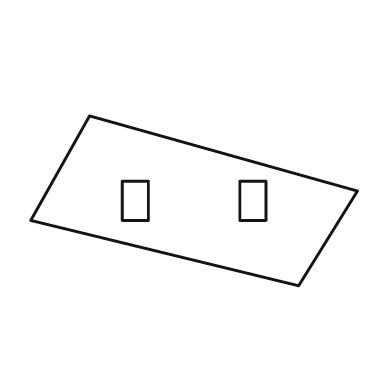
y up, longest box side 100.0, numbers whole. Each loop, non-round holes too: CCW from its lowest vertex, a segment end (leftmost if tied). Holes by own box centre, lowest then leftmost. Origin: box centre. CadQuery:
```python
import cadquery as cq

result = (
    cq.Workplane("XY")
    .moveTo(32.0, -26.0)
    .lineTo(50.0, 3.0)
    .lineTo(-32.0, 26.0)
    .lineTo(-50.0, -6.0)
    .close()
    .moveTo(-22.0, -6.0)
    .lineTo(-14.0, -6.0)
    .lineTo(-14.0, 6.0)
    .lineTo(-22.0, 6.0)
    .close()
    .moveTo(14.0, -6.0)
    .lineTo(22.0, -6.0)
    .lineTo(22.0, 6.0)
    .lineTo(14.0, 6.0)
    .close()
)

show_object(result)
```